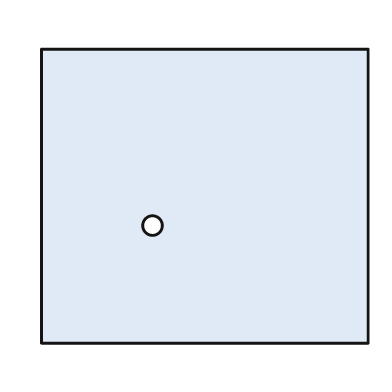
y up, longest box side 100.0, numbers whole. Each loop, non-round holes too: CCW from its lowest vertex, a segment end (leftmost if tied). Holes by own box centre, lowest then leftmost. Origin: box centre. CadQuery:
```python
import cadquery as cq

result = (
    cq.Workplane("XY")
    .moveTo(-50.0, -45.0)
    .lineTo(50.0, -45.0)
    .lineTo(50.0, 45.0)
    .lineTo(-50.0, 45.0)
    .close()
    .moveTo(-16.0, -9.0)
    .circle(3.0)
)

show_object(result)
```